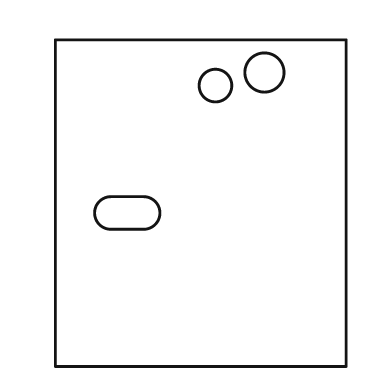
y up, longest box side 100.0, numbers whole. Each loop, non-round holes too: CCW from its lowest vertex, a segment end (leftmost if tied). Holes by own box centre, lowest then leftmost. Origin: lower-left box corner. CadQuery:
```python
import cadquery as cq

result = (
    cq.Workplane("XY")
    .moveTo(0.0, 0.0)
    .lineTo(89.0, 0.0)
    .lineTo(89.0, 100.0)
    .lineTo(0.0, 100.0)
    .close()
    .moveTo(17.0, 42.0)
    .lineTo(27.0, 42.0)
    .threePointArc((32.0, 47.0), (27.0, 52.0))
    .lineTo(17.0, 52.0)
    .threePointArc((12.0, 47.0), (17.0, 42.0))
    .close()
    .moveTo(49.0, 86.0)
    .circle(5.0)
    .moveTo(64.0, 90.0)
    .circle(6.0)
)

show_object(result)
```